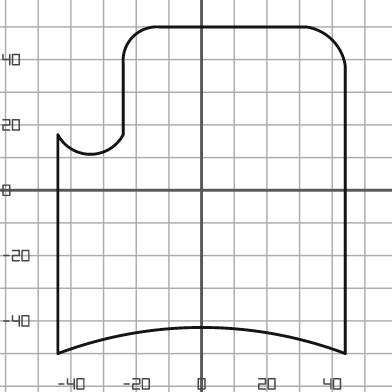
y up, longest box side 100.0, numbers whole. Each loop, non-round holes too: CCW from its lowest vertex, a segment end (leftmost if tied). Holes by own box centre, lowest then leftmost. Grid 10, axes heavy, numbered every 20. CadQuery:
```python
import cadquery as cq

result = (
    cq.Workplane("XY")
    .moveTo(-44.0, -50.0)
    .threePointArc((0.0, -42.0), (44.0, -50.0))
    .lineTo(44.0, 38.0)
    .threePointArc((40.0, 46.0), (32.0, 50.0))
    .lineTo(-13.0, 50.0)
    .threePointArc((-21.0, 47.0), (-24.0, 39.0))
    .lineTo(-24.0, 17.0)
    .threePointArc((-34.0, 11.0), (-44.0, 17.0))
    .close()
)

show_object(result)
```